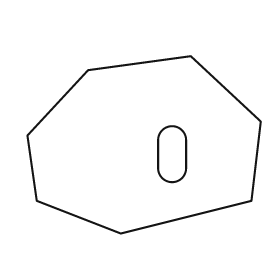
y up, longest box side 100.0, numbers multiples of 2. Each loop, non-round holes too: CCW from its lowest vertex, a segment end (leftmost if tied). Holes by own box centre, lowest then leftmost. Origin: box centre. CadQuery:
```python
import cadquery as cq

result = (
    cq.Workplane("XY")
    .moveTo(-10.0, -38.0)
    .lineTo(46.0, -24.0)
    .lineTo(50.0, 10.0)
    .lineTo(20.0, 38.0)
    .lineTo(-24.0, 32.0)
    .lineTo(-50.0, 4.0)
    .lineTo(-46.0, -24.0)
    .close()
    .moveTo(6.0, -10.0)
    .threePointArc((12.0, -16.0), (18.0, -10.0))
    .lineTo(18.0, 2.0)
    .threePointArc((12.0, 8.0), (6.0, 2.0))
    .close()
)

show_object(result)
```